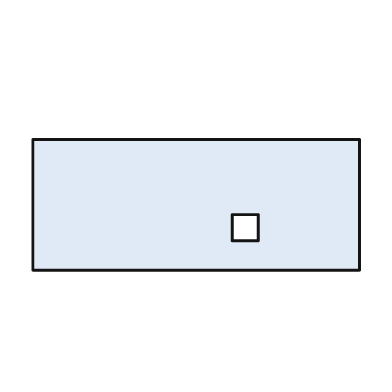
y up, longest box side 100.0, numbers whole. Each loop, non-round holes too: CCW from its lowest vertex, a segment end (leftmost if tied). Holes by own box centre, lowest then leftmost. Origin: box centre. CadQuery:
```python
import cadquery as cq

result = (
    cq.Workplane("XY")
    .moveTo(-50.0, -20.0)
    .lineTo(50.0, -20.0)
    .lineTo(50.0, 20.0)
    .lineTo(-50.0, 20.0)
    .close()
    .moveTo(11.0, -11.0)
    .lineTo(19.0, -11.0)
    .lineTo(19.0, -3.0)
    .lineTo(11.0, -3.0)
    .close()
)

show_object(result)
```